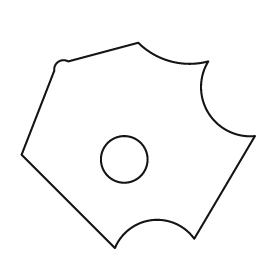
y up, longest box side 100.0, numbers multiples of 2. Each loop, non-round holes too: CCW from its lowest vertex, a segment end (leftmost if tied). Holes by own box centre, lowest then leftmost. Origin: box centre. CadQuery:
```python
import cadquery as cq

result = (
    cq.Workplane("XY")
    .moveTo(-10.0, -44.0)
    .threePointArc((6.0, -32.0), (24.0, -40.0))
    .lineTo(50.0, 4.0)
    .threePointArc((30.0, 14.0), (30.0, 36.0))
    .threePointArc((14.0, 36.0), (0.0, 44.0))
    .lineTo(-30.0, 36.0)
    .threePointArc((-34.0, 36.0), (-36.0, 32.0))
    .lineTo(-50.0, -4.0)
    .close()
    .moveTo(-6.0, -6.0)
    .circle(10.0)
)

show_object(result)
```